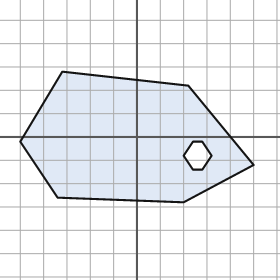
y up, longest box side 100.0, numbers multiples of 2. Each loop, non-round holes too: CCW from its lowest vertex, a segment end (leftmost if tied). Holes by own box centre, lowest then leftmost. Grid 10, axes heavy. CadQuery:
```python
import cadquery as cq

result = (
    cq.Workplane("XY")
    .moveTo(20.0, -28.0)
    .lineTo(50.0, -12.0)
    .lineTo(22.0, 22.0)
    .lineTo(-32.0, 28.0)
    .lineTo(-50.0, -2.0)
    .lineTo(-34.0, -26.0)
    .close()
    .moveTo(24.0, -14.0)
    .lineTo(28.0, -14.0)
    .lineTo(32.0, -8.0)
    .lineTo(28.0, -2.0)
    .lineTo(24.0, -2.0)
    .lineTo(20.0, -8.0)
    .close()
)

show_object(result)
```